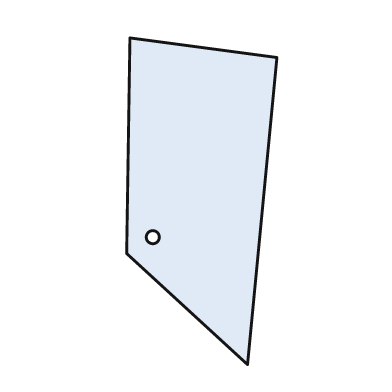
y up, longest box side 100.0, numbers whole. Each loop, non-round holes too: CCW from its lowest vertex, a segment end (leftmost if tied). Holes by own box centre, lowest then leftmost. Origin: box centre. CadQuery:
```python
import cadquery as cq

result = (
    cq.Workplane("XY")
    .moveTo(14.0, -50.0)
    .lineTo(23.0, 44.0)
    .lineTo(-22.0, 50.0)
    .lineTo(-23.0, -16.0)
    .close()
    .moveTo(-15.0, -11.0)
    .circle(2.0)
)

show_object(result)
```